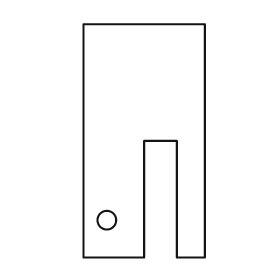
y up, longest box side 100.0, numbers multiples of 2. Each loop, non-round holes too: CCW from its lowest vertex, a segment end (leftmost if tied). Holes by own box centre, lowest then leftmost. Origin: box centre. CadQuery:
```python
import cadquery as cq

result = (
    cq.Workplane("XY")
    .moveTo(-26.0, -50.0)
    .lineTo(0.0, -50.0)
    .lineTo(0.0, 0.0)
    .lineTo(14.0, 0.0)
    .lineTo(14.0, -50.0)
    .lineTo(26.0, -50.0)
    .lineTo(26.0, 50.0)
    .lineTo(-26.0, 50.0)
    .close()
    .moveTo(-16.0, -34.0)
    .circle(4.0)
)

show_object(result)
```